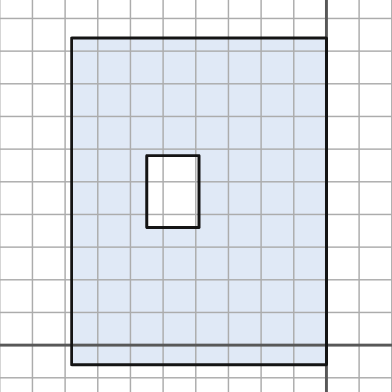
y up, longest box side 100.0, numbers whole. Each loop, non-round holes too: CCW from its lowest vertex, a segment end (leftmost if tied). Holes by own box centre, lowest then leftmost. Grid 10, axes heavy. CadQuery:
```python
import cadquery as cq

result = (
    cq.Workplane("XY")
    .moveTo(-78.0, -6.0)
    .lineTo(0.0, -6.0)
    .lineTo(0.0, 94.0)
    .lineTo(-78.0, 94.0)
    .close()
    .moveTo(-55.0, 36.0)
    .lineTo(-39.0, 36.0)
    .lineTo(-39.0, 58.0)
    .lineTo(-55.0, 58.0)
    .close()
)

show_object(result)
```